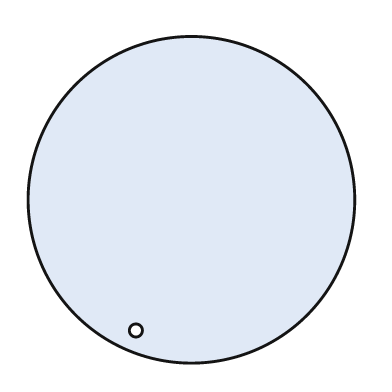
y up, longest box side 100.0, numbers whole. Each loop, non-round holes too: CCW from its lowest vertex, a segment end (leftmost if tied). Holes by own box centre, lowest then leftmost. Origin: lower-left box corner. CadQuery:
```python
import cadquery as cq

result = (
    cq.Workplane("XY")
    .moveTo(50.0, 50.0)
    .circle(50.0)
    .moveTo(33.0, 10.0)
    .circle(2.0)
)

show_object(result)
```